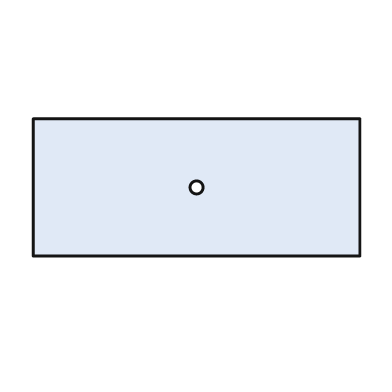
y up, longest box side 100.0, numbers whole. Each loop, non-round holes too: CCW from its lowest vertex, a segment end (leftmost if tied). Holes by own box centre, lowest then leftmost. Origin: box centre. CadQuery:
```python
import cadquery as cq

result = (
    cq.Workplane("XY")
    .moveTo(-50.0, -21.0)
    .lineTo(50.0, -21.0)
    .lineTo(50.0, 21.0)
    .lineTo(-50.0, 21.0)
    .close()
    .moveTo(0.0, 0.0)
    .circle(2.0)
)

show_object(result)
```